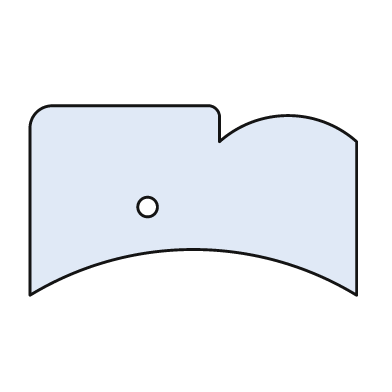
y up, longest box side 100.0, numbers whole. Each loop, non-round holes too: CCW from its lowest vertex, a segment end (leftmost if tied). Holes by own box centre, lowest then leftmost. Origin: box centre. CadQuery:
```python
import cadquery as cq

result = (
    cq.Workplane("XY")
    .moveTo(-50.0, -29.0)
    .threePointArc((0.0, -15.0), (50.0, -29.0))
    .lineTo(50.0, 18.0)
    .threePointArc((29.0, 26.0), (8.0, 18.0))
    .lineTo(8.0, 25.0)
    .threePointArc((7.0, 28.0), (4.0, 29.0))
    .lineTo(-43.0, 29.0)
    .threePointArc((-48.0, 27.0), (-50.0, 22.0))
    .close()
    .moveTo(-14.0, -2.0)
    .circle(3.0)
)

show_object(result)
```